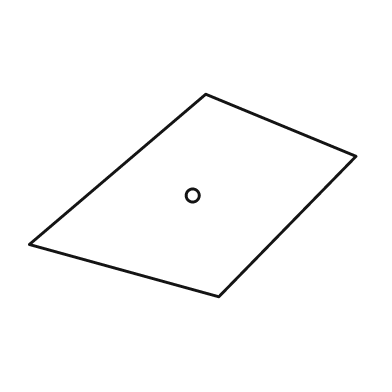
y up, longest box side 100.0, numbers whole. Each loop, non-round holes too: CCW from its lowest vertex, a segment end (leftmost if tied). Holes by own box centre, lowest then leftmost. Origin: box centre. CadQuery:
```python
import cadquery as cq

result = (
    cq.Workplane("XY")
    .moveTo(8.0, -31.0)
    .lineTo(50.0, 12.0)
    .lineTo(4.0, 31.0)
    .lineTo(-50.0, -15.0)
    .close()
    .moveTo(0.0, 0.0)
    .circle(2.0)
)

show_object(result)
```